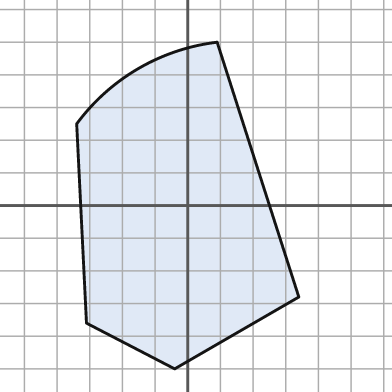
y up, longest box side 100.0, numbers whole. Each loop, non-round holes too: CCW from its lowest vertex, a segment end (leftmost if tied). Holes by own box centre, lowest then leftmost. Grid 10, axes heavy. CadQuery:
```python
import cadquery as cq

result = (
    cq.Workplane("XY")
    .moveTo(-4.0, -50.0)
    .lineTo(34.0, -28.0)
    .lineTo(9.0, 50.0)
    .threePointArc((-15.0, 42.0), (-34.0, 25.0))
    .lineTo(-31.0, -36.0)
    .close()
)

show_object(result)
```